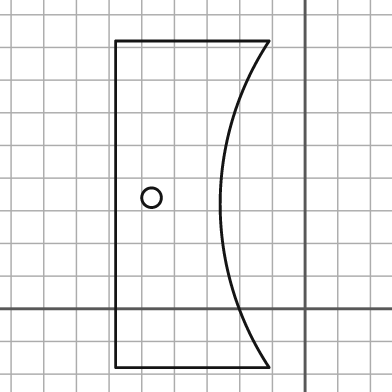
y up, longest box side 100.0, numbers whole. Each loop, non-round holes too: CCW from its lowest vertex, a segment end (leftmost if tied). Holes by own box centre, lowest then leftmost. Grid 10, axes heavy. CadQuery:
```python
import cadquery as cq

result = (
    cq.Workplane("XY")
    .moveTo(-58.0, -18.0)
    .lineTo(-11.0, -18.0)
    .threePointArc((-26.0, 32.0), (-11.0, 82.0))
    .lineTo(-58.0, 82.0)
    .close()
    .moveTo(-47.0, 34.0)
    .circle(3.0)
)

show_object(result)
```